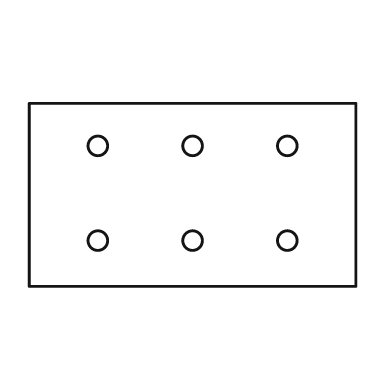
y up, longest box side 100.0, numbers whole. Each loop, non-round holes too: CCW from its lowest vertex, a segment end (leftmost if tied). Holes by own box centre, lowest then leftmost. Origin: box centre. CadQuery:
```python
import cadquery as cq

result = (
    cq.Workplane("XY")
    .moveTo(-50.0, -28.0)
    .lineTo(50.0, -28.0)
    .lineTo(50.0, 28.0)
    .lineTo(-50.0, 28.0)
    .close()
    .moveTo(-29.0, -14.0)
    .circle(3.0)
    .moveTo(0.0, -14.0)
    .circle(3.0)
    .moveTo(29.0, -14.0)
    .circle(3.0)
    .moveTo(-29.0, 15.0)
    .circle(3.0)
    .moveTo(0.0, 15.0)
    .circle(3.0)
    .moveTo(29.0, 15.0)
    .circle(3.0)
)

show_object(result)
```